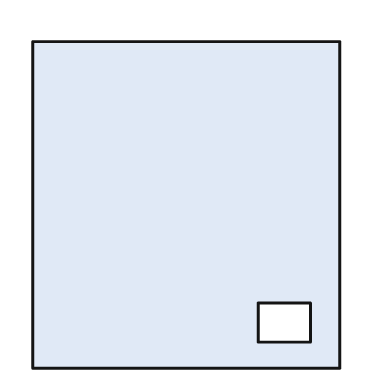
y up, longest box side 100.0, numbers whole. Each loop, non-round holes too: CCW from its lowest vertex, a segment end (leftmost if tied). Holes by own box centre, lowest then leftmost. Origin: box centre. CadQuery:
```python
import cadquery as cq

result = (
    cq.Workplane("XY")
    .moveTo(-47.0, -50.0)
    .lineTo(47.0, -50.0)
    .lineTo(47.0, 50.0)
    .lineTo(-47.0, 50.0)
    .close()
    .moveTo(22.0, -42.0)
    .lineTo(38.0, -42.0)
    .lineTo(38.0, -30.0)
    .lineTo(22.0, -30.0)
    .close()
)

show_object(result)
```